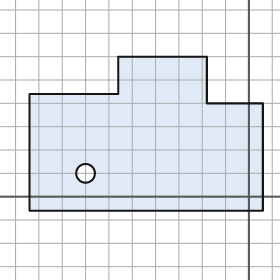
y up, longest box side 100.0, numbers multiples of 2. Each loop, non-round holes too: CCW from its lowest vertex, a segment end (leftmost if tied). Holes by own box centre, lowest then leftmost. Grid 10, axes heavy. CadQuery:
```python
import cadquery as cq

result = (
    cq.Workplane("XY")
    .moveTo(-94.0, -6.0)
    .lineTo(6.0, -6.0)
    .lineTo(6.0, 40.0)
    .lineTo(-18.0, 40.0)
    .lineTo(-18.0, 60.0)
    .lineTo(-56.0, 60.0)
    .lineTo(-56.0, 44.0)
    .lineTo(-94.0, 44.0)
    .close()
    .moveTo(-70.0, 10.0)
    .circle(4.0)
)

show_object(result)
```